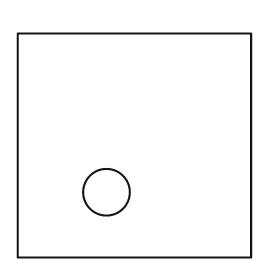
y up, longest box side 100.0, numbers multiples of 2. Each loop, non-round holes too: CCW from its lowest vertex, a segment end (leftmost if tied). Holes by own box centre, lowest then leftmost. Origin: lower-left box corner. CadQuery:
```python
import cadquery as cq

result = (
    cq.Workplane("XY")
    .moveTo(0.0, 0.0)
    .lineTo(100.0, 0.0)
    .lineTo(100.0, 96.0)
    .lineTo(0.0, 96.0)
    .close()
    .moveTo(38.0, 28.0)
    .circle(10.0)
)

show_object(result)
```